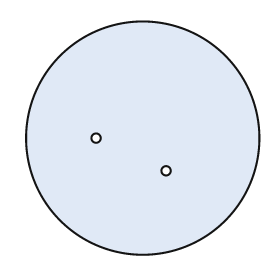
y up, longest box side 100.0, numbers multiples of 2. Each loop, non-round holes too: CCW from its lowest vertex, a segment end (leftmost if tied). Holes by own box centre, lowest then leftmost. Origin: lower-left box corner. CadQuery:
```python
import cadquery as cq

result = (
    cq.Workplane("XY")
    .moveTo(50.0, 50.0)
    .circle(50.0)
    .moveTo(60.0, 36.0)
    .circle(2.0)
    .moveTo(30.0, 50.0)
    .circle(2.0)
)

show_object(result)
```